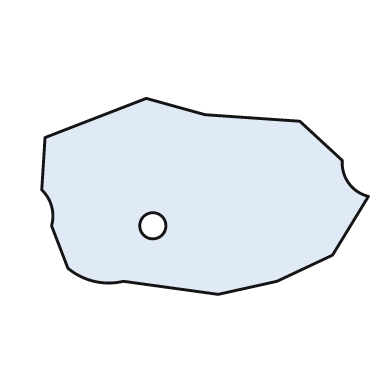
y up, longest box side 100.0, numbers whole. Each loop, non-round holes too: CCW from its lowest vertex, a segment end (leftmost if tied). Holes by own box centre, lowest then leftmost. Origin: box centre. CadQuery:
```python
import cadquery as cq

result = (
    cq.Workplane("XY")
    .moveTo(4.0, -30.0)
    .lineTo(22.0, -26.0)
    .lineTo(39.0, -18.0)
    .lineTo(50.0, 0.0)
    .threePointArc((44.0, 4.0), (42.0, 11.0))
    .lineTo(29.0, 23.0)
    .lineTo(0.0, 25.0)
    .lineTo(-18.0, 30.0)
    .lineTo(-49.0, 18.0)
    .lineTo(-50.0, 2.0)
    .threePointArc((-47.0, -3.0), (-47.0, -9.0))
    .lineTo(-42.0, -22.0)
    .threePointArc((-34.0, -26.0), (-25.0, -26.0))
    .close()
    .moveTo(-16.0, -9.0)
    .circle(4.0)
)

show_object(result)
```